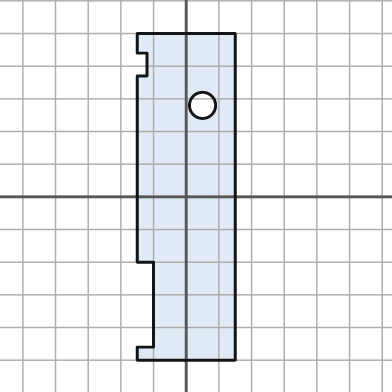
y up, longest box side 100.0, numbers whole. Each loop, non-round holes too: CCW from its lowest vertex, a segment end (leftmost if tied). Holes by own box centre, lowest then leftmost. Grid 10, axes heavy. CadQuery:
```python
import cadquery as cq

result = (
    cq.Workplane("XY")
    .moveTo(-15.0, -50.0)
    .lineTo(15.0, -50.0)
    .lineTo(15.0, 50.0)
    .lineTo(-15.0, 50.0)
    .lineTo(-15.0, 44.0)
    .lineTo(-12.0, 44.0)
    .lineTo(-12.0, 37.0)
    .lineTo(-15.0, 37.0)
    .lineTo(-15.0, -20.0)
    .lineTo(-10.0, -20.0)
    .lineTo(-10.0, -46.0)
    .lineTo(-15.0, -46.0)
    .close()
    .moveTo(5.0, 28.0)
    .circle(4.0)
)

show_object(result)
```